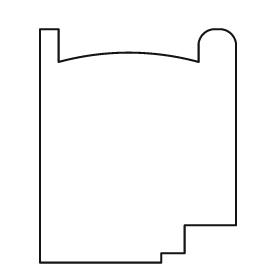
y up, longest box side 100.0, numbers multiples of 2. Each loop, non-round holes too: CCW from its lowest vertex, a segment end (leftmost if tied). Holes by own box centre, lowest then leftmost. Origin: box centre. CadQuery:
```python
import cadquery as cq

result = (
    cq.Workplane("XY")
    .moveTo(-42.0, -50.0)
    .lineTo(10.0, -50.0)
    .lineTo(10.0, -46.0)
    .lineTo(20.0, -46.0)
    .lineTo(20.0, -34.0)
    .lineTo(42.0, -34.0)
    .lineTo(42.0, 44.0)
    .threePointArc((40.0, 48.0), (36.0, 50.0))
    .lineTo(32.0, 50.0)
    .threePointArc((28.0, 48.0), (26.0, 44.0))
    .lineTo(26.0, 36.0)
    .threePointArc((-4.0, 40.0), (-34.0, 36.0))
    .lineTo(-34.0, 50.0)
    .lineTo(-42.0, 50.0)
    .close()
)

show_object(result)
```